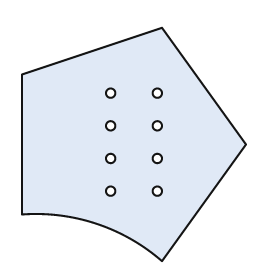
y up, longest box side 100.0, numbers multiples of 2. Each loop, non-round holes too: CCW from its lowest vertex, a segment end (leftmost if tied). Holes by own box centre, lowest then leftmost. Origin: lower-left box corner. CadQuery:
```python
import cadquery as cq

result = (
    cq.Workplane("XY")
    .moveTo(60.0, 0.0)
    .lineTo(96.0, 50.0)
    .lineTo(60.0, 100.0)
    .lineTo(0.0, 80.0)
    .lineTo(0.0, 20.0)
    .threePointArc((32.0, 16.0), (60.0, 0.0))
    .close()
    .moveTo(38.0, 30.0)
    .circle(2.0)
    .moveTo(58.0, 30.0)
    .circle(2.0)
    .moveTo(38.0, 44.0)
    .circle(2.0)
    .moveTo(58.0, 44.0)
    .circle(2.0)
    .moveTo(38.0, 58.0)
    .circle(2.0)
    .moveTo(58.0, 58.0)
    .circle(2.0)
    .moveTo(38.0, 72.0)
    .circle(2.0)
    .moveTo(58.0, 72.0)
    .circle(2.0)
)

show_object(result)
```